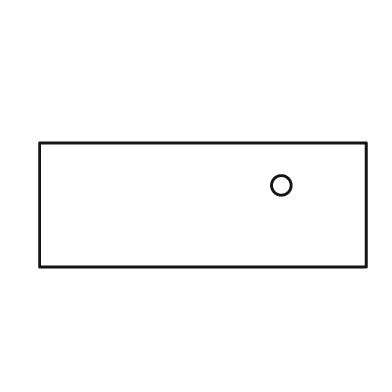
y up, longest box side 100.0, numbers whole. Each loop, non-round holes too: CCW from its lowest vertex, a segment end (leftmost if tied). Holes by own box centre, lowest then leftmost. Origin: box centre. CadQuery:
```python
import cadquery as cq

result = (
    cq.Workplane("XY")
    .moveTo(-50.0, -19.0)
    .lineTo(50.0, -19.0)
    .lineTo(50.0, 19.0)
    .lineTo(-50.0, 19.0)
    .close()
    .moveTo(24.0, 6.0)
    .circle(3.0)
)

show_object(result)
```